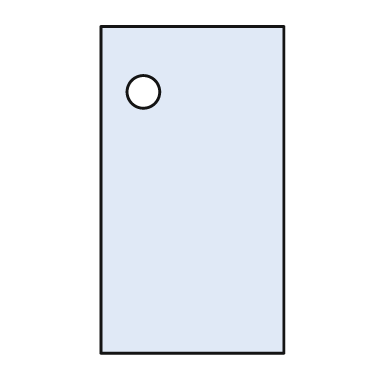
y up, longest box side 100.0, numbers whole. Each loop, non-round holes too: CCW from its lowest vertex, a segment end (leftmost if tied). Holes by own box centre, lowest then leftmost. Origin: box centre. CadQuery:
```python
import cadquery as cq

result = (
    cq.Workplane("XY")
    .moveTo(-28.0, -50.0)
    .lineTo(28.0, -50.0)
    .lineTo(28.0, 50.0)
    .lineTo(-28.0, 50.0)
    .close()
    .moveTo(-15.0, 30.0)
    .circle(5.0)
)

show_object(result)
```